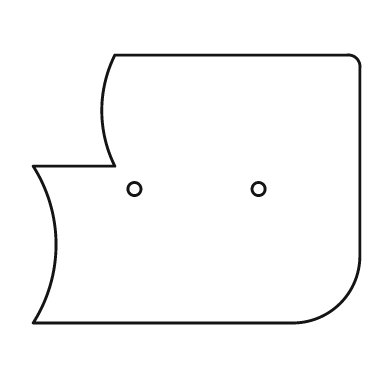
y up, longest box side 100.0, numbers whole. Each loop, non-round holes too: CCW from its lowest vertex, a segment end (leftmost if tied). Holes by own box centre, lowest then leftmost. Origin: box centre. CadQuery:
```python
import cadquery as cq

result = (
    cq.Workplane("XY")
    .moveTo(-50.0, -41.0)
    .lineTo(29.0, -41.0)
    .threePointArc((44.0, -35.0), (50.0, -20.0))
    .lineTo(50.0, 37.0)
    .threePointArc((49.0, 40.0), (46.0, 41.0))
    .lineTo(-25.0, 41.0)
    .threePointArc((-29.0, 24.0), (-25.0, 7.0))
    .lineTo(-50.0, 7.0)
    .threePointArc((-43.0, -17.0), (-50.0, -41.0))
    .close()
    .moveTo(-19.0, 0.0)
    .circle(2.0)
    .moveTo(19.0, 0.0)
    .circle(2.0)
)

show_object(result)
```